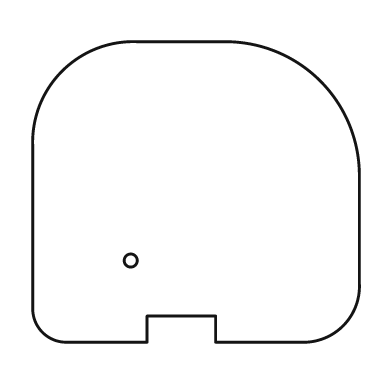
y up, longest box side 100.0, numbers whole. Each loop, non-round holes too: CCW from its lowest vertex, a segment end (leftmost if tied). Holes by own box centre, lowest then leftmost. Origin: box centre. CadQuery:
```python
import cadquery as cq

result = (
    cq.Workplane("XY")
    .moveTo(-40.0, -46.0)
    .lineTo(-15.0, -46.0)
    .lineTo(-15.0, -38.0)
    .lineTo(6.0, -38.0)
    .lineTo(6.0, -46.0)
    .lineTo(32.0, -46.0)
    .threePointArc((45.0, -41.0), (50.0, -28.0))
    .lineTo(50.0, 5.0)
    .threePointArc((38.0, 34.0), (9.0, 46.0))
    .lineTo(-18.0, 46.0)
    .threePointArc((-41.0, 37.0), (-50.0, 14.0))
    .lineTo(-50.0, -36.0)
    .threePointArc((-47.0, -43.0), (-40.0, -46.0))
    .close()
    .moveTo(-20.0, -21.0)
    .circle(2.0)
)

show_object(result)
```